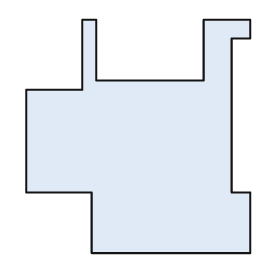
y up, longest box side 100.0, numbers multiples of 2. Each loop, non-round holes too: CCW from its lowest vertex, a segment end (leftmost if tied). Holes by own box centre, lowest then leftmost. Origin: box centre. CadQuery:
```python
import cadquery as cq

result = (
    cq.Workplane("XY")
    .moveTo(-20.0, -50.0)
    .lineTo(48.0, -50.0)
    .lineTo(48.0, -24.0)
    .lineTo(40.0, -24.0)
    .lineTo(40.0, 42.0)
    .lineTo(48.0, 42.0)
    .lineTo(48.0, 50.0)
    .lineTo(28.0, 50.0)
    .lineTo(28.0, 24.0)
    .lineTo(-18.0, 24.0)
    .lineTo(-18.0, 50.0)
    .lineTo(-24.0, 50.0)
    .lineTo(-24.0, 20.0)
    .lineTo(-48.0, 20.0)
    .lineTo(-48.0, -24.0)
    .lineTo(-20.0, -24.0)
    .close()
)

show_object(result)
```